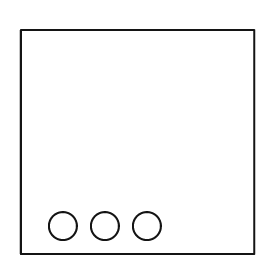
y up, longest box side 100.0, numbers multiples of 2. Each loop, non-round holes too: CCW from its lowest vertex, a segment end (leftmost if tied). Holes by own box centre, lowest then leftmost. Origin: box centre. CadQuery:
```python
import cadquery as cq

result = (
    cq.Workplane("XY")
    .moveTo(-50.0, -48.0)
    .lineTo(50.0, -48.0)
    .lineTo(50.0, 48.0)
    .lineTo(-50.0, 48.0)
    .close()
    .moveTo(-32.0, -36.0)
    .circle(6.0)
    .moveTo(-14.0, -36.0)
    .circle(6.0)
    .moveTo(4.0, -36.0)
    .circle(6.0)
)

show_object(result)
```